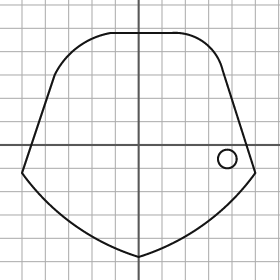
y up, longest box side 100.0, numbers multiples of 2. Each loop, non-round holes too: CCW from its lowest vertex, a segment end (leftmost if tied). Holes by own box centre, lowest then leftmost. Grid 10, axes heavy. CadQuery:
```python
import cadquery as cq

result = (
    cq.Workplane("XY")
    .moveTo(0.0, -48.0)
    .threePointArc((28.0, -34.0), (50.0, -12.0))
    .lineTo(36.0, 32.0)
    .threePointArc((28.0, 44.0), (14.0, 48.0))
    .lineTo(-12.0, 48.0)
    .threePointArc((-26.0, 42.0), (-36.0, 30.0))
    .lineTo(-50.0, -12.0)
    .threePointArc((-28.0, -34.0), (0.0, -48.0))
    .close()
    .moveTo(38.0, -6.0)
    .circle(4.0)
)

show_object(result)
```